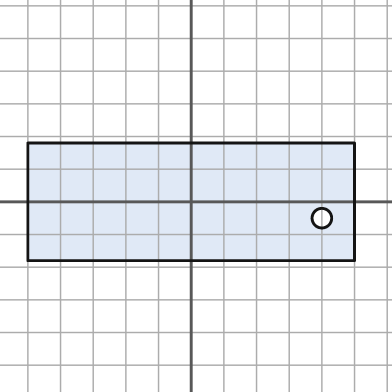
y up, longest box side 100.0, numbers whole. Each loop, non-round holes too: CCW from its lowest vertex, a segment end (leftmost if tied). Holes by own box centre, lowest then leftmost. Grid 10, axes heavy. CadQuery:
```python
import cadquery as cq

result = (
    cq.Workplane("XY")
    .moveTo(-50.0, -18.0)
    .lineTo(50.0, -18.0)
    .lineTo(50.0, 18.0)
    .lineTo(-50.0, 18.0)
    .close()
    .moveTo(40.0, -5.0)
    .circle(3.0)
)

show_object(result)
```